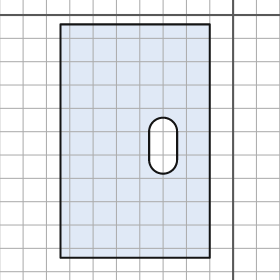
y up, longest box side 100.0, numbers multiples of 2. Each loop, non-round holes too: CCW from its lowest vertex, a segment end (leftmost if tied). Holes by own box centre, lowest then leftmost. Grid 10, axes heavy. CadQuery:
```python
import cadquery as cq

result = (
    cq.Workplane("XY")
    .moveTo(-74.0, -104.0)
    .lineTo(-10.0, -104.0)
    .lineTo(-10.0, -4.0)
    .lineTo(-74.0, -4.0)
    .close()
    .moveTo(-36.0, -62.0)
    .threePointArc((-30.0, -68.0), (-24.0, -62.0))
    .lineTo(-24.0, -50.0)
    .threePointArc((-30.0, -44.0), (-36.0, -50.0))
    .close()
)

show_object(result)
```